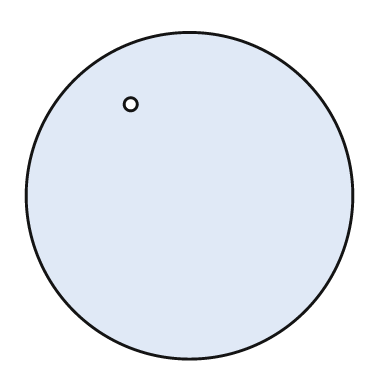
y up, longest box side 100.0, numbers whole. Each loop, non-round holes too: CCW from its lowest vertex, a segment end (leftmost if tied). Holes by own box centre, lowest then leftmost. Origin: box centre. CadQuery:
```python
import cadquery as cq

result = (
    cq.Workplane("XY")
    .moveTo(0.0, 0.0)
    .circle(50.0)
    .moveTo(-18.0, 28.0)
    .circle(2.0)
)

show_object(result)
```